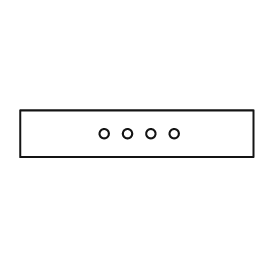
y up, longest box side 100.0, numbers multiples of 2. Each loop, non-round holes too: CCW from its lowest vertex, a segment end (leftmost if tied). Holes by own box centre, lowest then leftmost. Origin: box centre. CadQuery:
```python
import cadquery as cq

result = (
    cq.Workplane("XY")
    .moveTo(-50.0, -10.0)
    .lineTo(50.0, -10.0)
    .lineTo(50.0, 10.0)
    .lineTo(-50.0, 10.0)
    .close()
    .moveTo(-14.0, 0.0)
    .circle(2.0)
    .moveTo(-4.0, 0.0)
    .circle(2.0)
    .moveTo(6.0, 0.0)
    .circle(2.0)
    .moveTo(16.0, 0.0)
    .circle(2.0)
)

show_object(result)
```